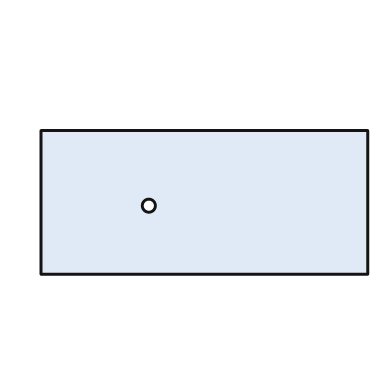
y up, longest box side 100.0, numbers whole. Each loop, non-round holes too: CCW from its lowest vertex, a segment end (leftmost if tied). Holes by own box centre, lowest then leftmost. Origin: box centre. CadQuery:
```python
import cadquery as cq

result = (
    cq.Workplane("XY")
    .moveTo(-50.0, -22.0)
    .lineTo(50.0, -22.0)
    .lineTo(50.0, 22.0)
    .lineTo(-50.0, 22.0)
    .close()
    .moveTo(-17.0, -1.0)
    .circle(2.0)
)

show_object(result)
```